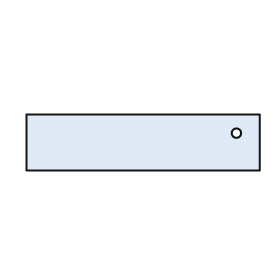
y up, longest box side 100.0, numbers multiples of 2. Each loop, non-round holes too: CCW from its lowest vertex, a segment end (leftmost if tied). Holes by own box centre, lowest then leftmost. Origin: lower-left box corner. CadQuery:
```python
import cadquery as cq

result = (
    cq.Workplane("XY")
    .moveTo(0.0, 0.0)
    .lineTo(100.0, 0.0)
    .lineTo(100.0, 24.0)
    .lineTo(0.0, 24.0)
    .close()
    .moveTo(90.0, 16.0)
    .circle(2.0)
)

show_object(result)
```